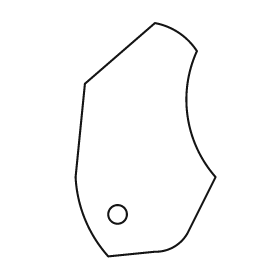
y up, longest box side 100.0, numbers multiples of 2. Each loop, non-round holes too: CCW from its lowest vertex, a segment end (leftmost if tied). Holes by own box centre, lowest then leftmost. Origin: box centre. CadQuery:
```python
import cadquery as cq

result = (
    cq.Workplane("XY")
    .moveTo(-16.0, -50.0)
    .lineTo(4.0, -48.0)
    .threePointArc((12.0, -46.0), (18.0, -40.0))
    .lineTo(30.0, -16.0)
    .threePointArc((18.0, 10.0), (22.0, 38.0))
    .threePointArc((14.0, 46.0), (4.0, 50.0))
    .lineTo(-26.0, 24.0)
    .lineTo(-30.0, -16.0)
    .threePointArc((-26.0, -34.0), (-16.0, -50.0))
    .close()
    .moveTo(-12.0, -32.0)
    .circle(4.0)
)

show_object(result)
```